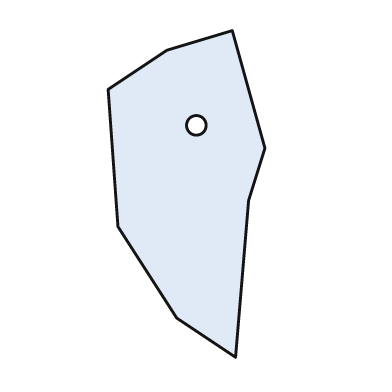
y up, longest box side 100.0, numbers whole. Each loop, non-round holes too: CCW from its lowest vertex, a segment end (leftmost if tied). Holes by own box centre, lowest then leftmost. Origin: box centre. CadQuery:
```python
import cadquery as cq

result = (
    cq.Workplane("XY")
    .moveTo(15.0, -50.0)
    .lineTo(19.0, -2.0)
    .lineTo(24.0, 14.0)
    .lineTo(14.0, 50.0)
    .lineTo(-6.0, 44.0)
    .lineTo(-24.0, 32.0)
    .lineTo(-21.0, -10.0)
    .lineTo(-3.0, -38.0)
    .close()
    .moveTo(3.0, 21.0)
    .circle(3.0)
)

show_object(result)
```